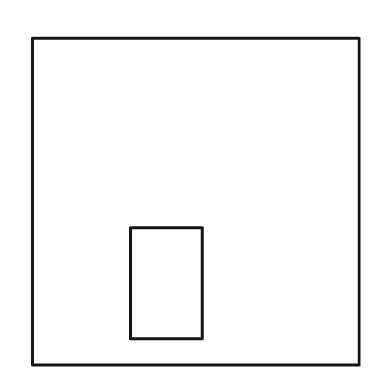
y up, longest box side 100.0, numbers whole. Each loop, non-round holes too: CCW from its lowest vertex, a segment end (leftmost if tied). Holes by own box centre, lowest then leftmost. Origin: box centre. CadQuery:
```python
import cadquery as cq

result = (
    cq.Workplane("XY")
    .moveTo(-50.0, -50.0)
    .lineTo(50.0, -50.0)
    .lineTo(50.0, 50.0)
    .lineTo(-50.0, 50.0)
    .close()
    .moveTo(-20.0, -42.0)
    .lineTo(2.0, -42.0)
    .lineTo(2.0, -8.0)
    .lineTo(-20.0, -8.0)
    .close()
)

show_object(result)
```